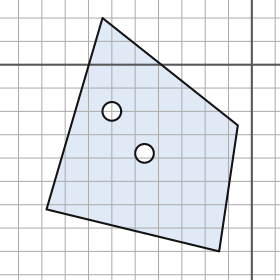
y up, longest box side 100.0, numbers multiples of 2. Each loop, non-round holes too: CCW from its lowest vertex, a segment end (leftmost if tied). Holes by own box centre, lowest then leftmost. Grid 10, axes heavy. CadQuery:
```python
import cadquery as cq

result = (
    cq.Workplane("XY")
    .moveTo(-14.0, -80.0)
    .lineTo(-6.0, -26.0)
    .lineTo(-64.0, 20.0)
    .lineTo(-88.0, -62.0)
    .close()
    .moveTo(-46.0, -38.0)
    .circle(4.0)
    .moveTo(-60.0, -20.0)
    .circle(4.0)
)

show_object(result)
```